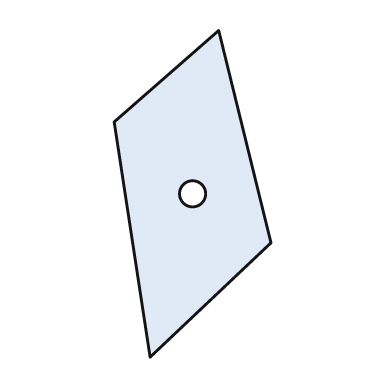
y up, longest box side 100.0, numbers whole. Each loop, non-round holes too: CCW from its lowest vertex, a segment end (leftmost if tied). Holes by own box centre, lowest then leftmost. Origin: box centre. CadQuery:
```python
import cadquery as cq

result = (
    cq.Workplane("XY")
    .moveTo(-13.0, -50.0)
    .lineTo(24.0, -15.0)
    .lineTo(8.0, 50.0)
    .lineTo(-24.0, 22.0)
    .close()
    .moveTo(0.0, 0.0)
    .circle(4.0)
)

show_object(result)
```